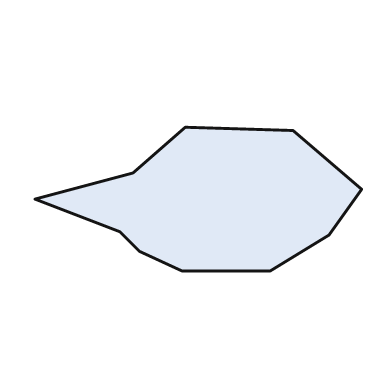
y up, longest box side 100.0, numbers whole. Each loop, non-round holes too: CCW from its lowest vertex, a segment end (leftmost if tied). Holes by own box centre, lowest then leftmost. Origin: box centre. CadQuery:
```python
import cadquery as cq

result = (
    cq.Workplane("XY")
    .moveTo(-5.0, -22.0)
    .lineTo(22.0, -22.0)
    .lineTo(40.0, -11.0)
    .lineTo(50.0, 3.0)
    .lineTo(29.0, 21.0)
    .lineTo(-4.0, 22.0)
    .lineTo(-20.0, 8.0)
    .lineTo(-50.0, 0.0)
    .lineTo(-24.0, -10.0)
    .lineTo(-18.0, -16.0)
    .close()
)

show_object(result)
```